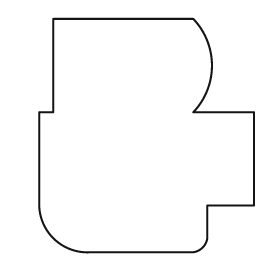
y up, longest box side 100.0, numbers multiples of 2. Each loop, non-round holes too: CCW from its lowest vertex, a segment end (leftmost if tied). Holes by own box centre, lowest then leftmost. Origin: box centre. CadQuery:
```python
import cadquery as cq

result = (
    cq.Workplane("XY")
    .moveTo(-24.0, -50.0)
    .lineTo(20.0, -50.0)
    .threePointArc((24.0, -48.0), (26.0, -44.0))
    .lineTo(26.0, -30.0)
    .lineTo(46.0, -30.0)
    .lineTo(46.0, 10.0)
    .lineTo(20.0, 10.0)
    .threePointArc((28.0, 30.0), (20.0, 50.0))
    .lineTo(-40.0, 50.0)
    .lineTo(-40.0, 10.0)
    .lineTo(-46.0, 10.0)
    .lineTo(-46.0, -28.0)
    .threePointArc((-40.0, -44.0), (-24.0, -50.0))
    .close()
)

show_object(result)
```